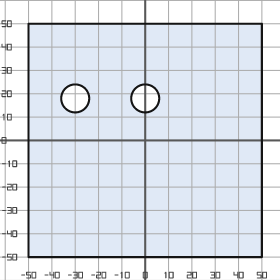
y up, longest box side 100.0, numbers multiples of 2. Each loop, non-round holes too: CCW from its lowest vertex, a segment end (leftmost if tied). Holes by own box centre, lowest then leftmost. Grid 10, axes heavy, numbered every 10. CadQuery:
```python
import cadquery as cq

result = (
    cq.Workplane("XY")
    .moveTo(-50.0, -50.0)
    .lineTo(50.0, -50.0)
    .lineTo(50.0, 50.0)
    .lineTo(-50.0, 50.0)
    .close()
    .moveTo(-30.0, 18.0)
    .circle(6.0)
    .moveTo(0.0, 18.0)
    .circle(6.0)
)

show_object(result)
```